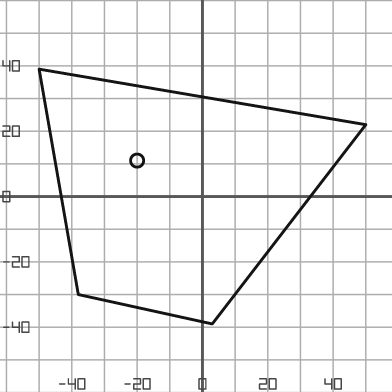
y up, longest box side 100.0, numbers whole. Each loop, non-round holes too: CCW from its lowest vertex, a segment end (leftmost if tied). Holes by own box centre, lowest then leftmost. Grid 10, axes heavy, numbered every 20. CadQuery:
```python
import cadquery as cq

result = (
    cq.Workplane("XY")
    .moveTo(3.0, -39.0)
    .lineTo(50.0, 22.0)
    .lineTo(-50.0, 39.0)
    .lineTo(-38.0, -30.0)
    .close()
    .moveTo(-20.0, 11.0)
    .circle(2.0)
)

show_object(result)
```